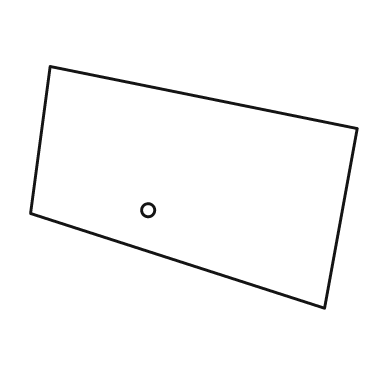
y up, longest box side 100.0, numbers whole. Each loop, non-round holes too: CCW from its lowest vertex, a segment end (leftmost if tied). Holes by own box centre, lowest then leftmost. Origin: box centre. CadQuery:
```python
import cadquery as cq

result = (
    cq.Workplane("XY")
    .moveTo(40.0, -37.0)
    .lineTo(50.0, 18.0)
    .lineTo(-44.0, 37.0)
    .lineTo(-50.0, -8.0)
    .close()
    .moveTo(-14.0, -7.0)
    .circle(2.0)
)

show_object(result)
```